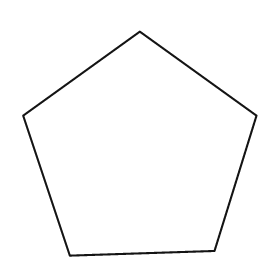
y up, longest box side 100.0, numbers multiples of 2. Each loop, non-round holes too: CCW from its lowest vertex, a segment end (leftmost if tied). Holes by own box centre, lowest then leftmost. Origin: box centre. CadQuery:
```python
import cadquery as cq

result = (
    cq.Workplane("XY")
    .moveTo(-30.0, -48.0)
    .lineTo(32.0, -46.0)
    .lineTo(50.0, 12.0)
    .lineTo(0.0, 48.0)
    .lineTo(-50.0, 12.0)
    .close()
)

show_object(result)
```